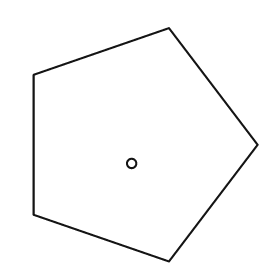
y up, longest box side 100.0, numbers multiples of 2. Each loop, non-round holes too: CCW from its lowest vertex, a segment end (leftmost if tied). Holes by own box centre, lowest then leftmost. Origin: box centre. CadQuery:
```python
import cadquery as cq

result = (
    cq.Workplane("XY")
    .moveTo(10.0, -50.0)
    .lineTo(48.0, 0.0)
    .lineTo(10.0, 50.0)
    .lineTo(-48.0, 30.0)
    .lineTo(-48.0, -30.0)
    .close()
    .moveTo(-6.0, -8.0)
    .circle(2.0)
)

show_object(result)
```